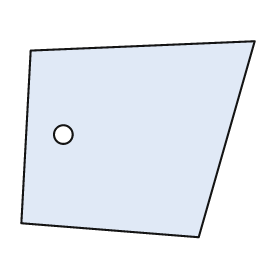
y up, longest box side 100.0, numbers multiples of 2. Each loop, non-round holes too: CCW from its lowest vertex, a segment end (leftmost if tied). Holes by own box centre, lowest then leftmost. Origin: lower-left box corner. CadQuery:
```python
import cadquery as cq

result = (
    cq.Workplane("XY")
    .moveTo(76.0, 0.0)
    .lineTo(100.0, 84.0)
    .lineTo(4.0, 80.0)
    .lineTo(0.0, 6.0)
    .close()
    .moveTo(18.0, 44.0)
    .circle(4.0)
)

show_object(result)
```